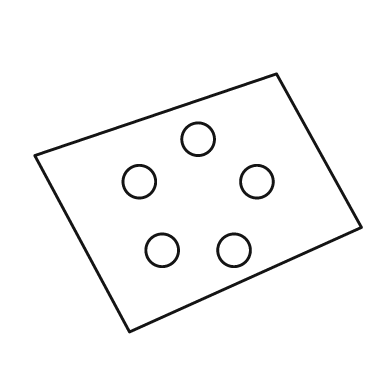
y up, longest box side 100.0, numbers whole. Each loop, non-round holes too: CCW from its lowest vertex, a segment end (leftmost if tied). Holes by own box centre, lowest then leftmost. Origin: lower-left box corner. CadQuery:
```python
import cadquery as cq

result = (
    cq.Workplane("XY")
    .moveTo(29.0, 0.0)
    .lineTo(100.0, 32.0)
    .lineTo(74.0, 79.0)
    .lineTo(0.0, 54.0)
    .close()
    .moveTo(39.0, 25.0)
    .circle(5.0)
    .moveTo(61.0, 25.0)
    .circle(5.0)
    .moveTo(32.0, 46.0)
    .circle(5.0)
    .moveTo(68.0, 46.0)
    .circle(5.0)
    .moveTo(50.0, 59.0)
    .circle(5.0)
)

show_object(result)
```